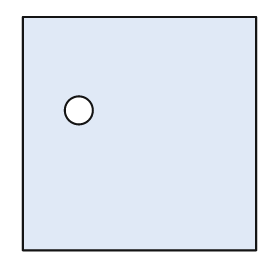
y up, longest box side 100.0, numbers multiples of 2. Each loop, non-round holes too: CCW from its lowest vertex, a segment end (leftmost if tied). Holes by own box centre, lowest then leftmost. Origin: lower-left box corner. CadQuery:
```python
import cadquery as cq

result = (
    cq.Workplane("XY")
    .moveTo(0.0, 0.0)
    .lineTo(100.0, 0.0)
    .lineTo(100.0, 100.0)
    .lineTo(0.0, 100.0)
    .close()
    .moveTo(24.0, 60.0)
    .circle(6.0)
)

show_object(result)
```